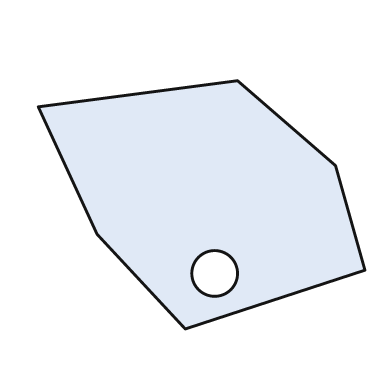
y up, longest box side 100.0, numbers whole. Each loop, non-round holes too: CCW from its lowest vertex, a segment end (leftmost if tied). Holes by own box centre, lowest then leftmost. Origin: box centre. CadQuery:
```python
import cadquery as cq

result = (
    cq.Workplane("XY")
    .moveTo(-5.0, -38.0)
    .lineTo(50.0, -20.0)
    .lineTo(41.0, 12.0)
    .lineTo(11.0, 38.0)
    .lineTo(-50.0, 30.0)
    .lineTo(-32.0, -9.0)
    .close()
    .moveTo(4.0, -21.0)
    .circle(7.0)
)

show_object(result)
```